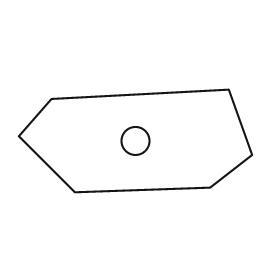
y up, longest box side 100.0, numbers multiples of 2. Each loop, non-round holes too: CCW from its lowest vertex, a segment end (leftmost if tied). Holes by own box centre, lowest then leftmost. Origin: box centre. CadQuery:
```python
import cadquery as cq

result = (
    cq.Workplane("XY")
    .moveTo(-26.0, -22.0)
    .lineTo(32.0, -20.0)
    .lineTo(50.0, -6.0)
    .lineTo(40.0, 22.0)
    .lineTo(-36.0, 18.0)
    .lineTo(-50.0, 2.0)
    .close()
    .moveTo(0.0, 0.0)
    .circle(6.0)
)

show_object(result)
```